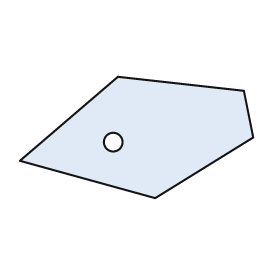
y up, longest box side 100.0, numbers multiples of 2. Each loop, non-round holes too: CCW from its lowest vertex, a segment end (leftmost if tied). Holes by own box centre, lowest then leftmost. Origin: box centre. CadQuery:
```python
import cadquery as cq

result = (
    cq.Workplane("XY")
    .moveTo(8.0, -26.0)
    .lineTo(50.0, 0.0)
    .lineTo(46.0, 20.0)
    .lineTo(-8.0, 26.0)
    .lineTo(-50.0, -10.0)
    .close()
    .moveTo(-10.0, -2.0)
    .circle(4.0)
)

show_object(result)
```